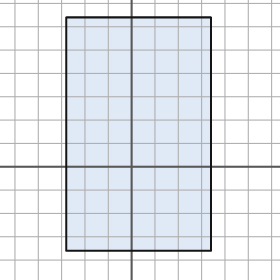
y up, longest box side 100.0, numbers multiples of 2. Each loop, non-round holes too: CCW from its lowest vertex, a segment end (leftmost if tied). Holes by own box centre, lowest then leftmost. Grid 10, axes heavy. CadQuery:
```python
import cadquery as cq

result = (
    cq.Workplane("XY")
    .moveTo(-28.0, -36.0)
    .lineTo(34.0, -36.0)
    .lineTo(34.0, 64.0)
    .lineTo(-28.0, 64.0)
    .close()
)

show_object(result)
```